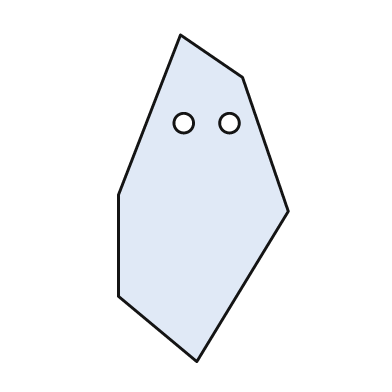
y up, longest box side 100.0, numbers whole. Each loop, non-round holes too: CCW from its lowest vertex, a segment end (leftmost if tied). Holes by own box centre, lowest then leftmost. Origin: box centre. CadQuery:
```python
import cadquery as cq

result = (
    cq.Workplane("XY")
    .moveTo(-2.0, -50.0)
    .lineTo(26.0, -4.0)
    .lineTo(12.0, 37.0)
    .lineTo(-7.0, 50.0)
    .lineTo(-26.0, 1.0)
    .lineTo(-26.0, -30.0)
    .close()
    .moveTo(-6.0, 23.0)
    .circle(3.0)
    .moveTo(8.0, 23.0)
    .circle(3.0)
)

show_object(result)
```